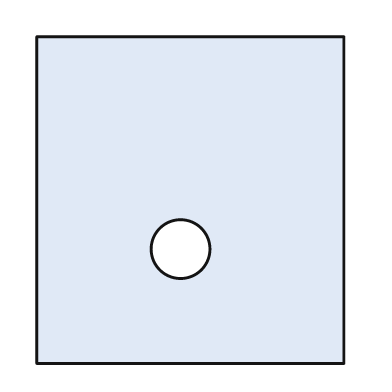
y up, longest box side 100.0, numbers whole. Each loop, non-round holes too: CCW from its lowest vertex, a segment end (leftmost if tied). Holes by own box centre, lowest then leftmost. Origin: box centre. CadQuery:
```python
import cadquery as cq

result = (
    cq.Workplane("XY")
    .moveTo(-47.0, -50.0)
    .lineTo(47.0, -50.0)
    .lineTo(47.0, 50.0)
    .lineTo(-47.0, 50.0)
    .close()
    .moveTo(-3.0, -15.0)
    .circle(9.0)
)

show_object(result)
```